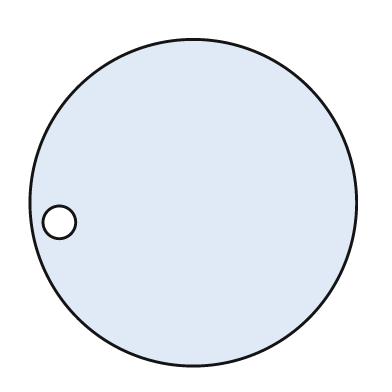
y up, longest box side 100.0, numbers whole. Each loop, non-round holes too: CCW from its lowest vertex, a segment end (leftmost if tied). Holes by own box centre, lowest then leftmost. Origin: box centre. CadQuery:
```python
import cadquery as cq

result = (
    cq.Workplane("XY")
    .moveTo(0.0, 0.0)
    .circle(50.0)
    .moveTo(-41.0, -6.0)
    .circle(5.0)
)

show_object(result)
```